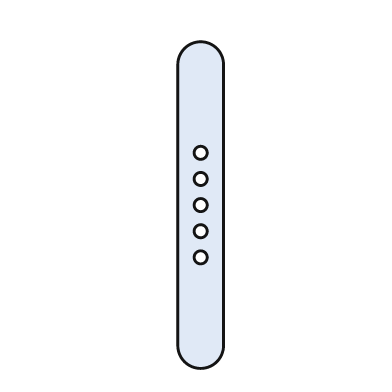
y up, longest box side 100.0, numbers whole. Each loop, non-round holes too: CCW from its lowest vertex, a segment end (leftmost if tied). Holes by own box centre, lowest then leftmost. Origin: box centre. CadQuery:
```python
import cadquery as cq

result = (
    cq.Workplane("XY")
    .moveTo(-7.0, -43.0)
    .threePointArc((0.0, -50.0), (7.0, -43.0))
    .lineTo(7.0, 43.0)
    .threePointArc((0.0, 50.0), (-7.0, 43.0))
    .close()
    .moveTo(0.0, -16.0)
    .circle(2.0)
    .moveTo(0.0, -8.0)
    .circle(2.0)
    .moveTo(0.0, 0.0)
    .circle(2.0)
    .moveTo(0.0, 8.0)
    .circle(2.0)
    .moveTo(0.0, 16.0)
    .circle(2.0)
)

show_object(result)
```